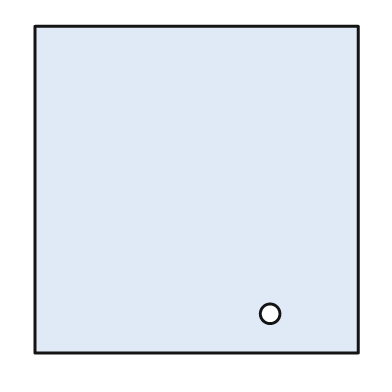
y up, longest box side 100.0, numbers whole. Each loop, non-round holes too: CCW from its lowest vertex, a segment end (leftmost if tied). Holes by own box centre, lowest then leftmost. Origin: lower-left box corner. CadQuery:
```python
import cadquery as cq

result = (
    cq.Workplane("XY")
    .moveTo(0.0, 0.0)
    .lineTo(99.0, 0.0)
    .lineTo(99.0, 100.0)
    .lineTo(0.0, 100.0)
    .close()
    .moveTo(72.0, 12.0)
    .circle(3.0)
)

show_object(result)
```